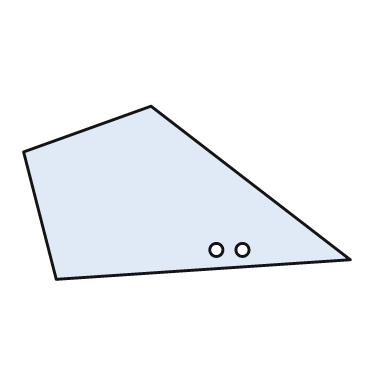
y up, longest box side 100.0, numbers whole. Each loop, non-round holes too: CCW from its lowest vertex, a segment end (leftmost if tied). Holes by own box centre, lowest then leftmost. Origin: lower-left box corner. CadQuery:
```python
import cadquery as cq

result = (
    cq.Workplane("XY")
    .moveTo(10.0, 0.0)
    .lineTo(100.0, 6.0)
    .lineTo(39.0, 53.0)
    .lineTo(0.0, 39.0)
    .close()
    .moveTo(59.0, 9.0)
    .circle(2.0)
    .moveTo(67.0, 9.0)
    .circle(2.0)
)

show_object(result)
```